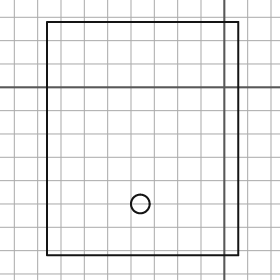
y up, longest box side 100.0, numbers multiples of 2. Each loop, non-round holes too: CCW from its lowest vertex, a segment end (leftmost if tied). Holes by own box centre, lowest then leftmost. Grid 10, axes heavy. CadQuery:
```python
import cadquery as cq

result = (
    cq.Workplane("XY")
    .moveTo(-76.0, -72.0)
    .lineTo(6.0, -72.0)
    .lineTo(6.0, 28.0)
    .lineTo(-76.0, 28.0)
    .close()
    .moveTo(-36.0, -50.0)
    .circle(4.0)
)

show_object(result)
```